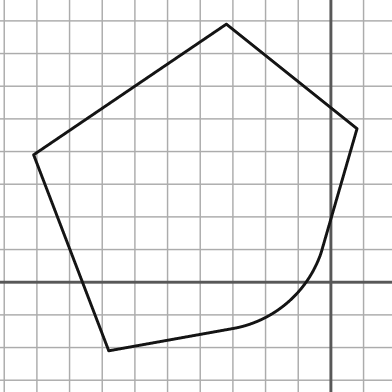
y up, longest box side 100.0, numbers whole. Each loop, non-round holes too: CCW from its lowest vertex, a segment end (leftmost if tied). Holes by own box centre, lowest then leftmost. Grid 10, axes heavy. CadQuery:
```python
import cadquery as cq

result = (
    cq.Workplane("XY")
    .moveTo(-68.0, -21.0)
    .lineTo(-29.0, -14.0)
    .threePointArc((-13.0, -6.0), (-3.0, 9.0))
    .lineTo(8.0, 47.0)
    .lineTo(-32.0, 79.0)
    .lineTo(-91.0, 39.0)
    .close()
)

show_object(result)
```